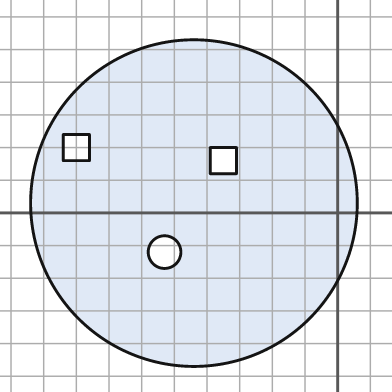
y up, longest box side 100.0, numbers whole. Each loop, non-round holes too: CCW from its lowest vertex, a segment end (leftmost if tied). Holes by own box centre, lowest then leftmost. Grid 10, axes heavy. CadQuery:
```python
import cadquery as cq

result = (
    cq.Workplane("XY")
    .moveTo(-44.0, 3.0)
    .circle(50.0)
    .moveTo(-53.0, -12.0)
    .circle(5.0)
    .moveTo(-39.0, 12.0)
    .lineTo(-31.0, 12.0)
    .lineTo(-31.0, 20.0)
    .lineTo(-39.0, 20.0)
    .close()
    .moveTo(-84.0, 16.0)
    .lineTo(-76.0, 16.0)
    .lineTo(-76.0, 24.0)
    .lineTo(-84.0, 24.0)
    .close()
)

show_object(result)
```